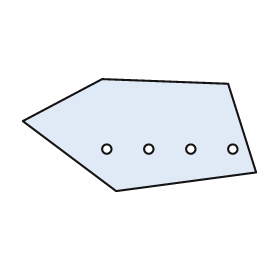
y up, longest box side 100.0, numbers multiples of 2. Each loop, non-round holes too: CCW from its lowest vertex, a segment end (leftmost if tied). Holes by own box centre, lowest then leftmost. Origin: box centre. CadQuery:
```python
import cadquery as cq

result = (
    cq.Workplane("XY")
    .moveTo(-10.0, -24.0)
    .lineTo(50.0, -16.0)
    .lineTo(38.0, 22.0)
    .lineTo(-16.0, 24.0)
    .lineTo(-50.0, 6.0)
    .close()
    .moveTo(-14.0, -6.0)
    .circle(2.0)
    .moveTo(4.0, -6.0)
    .circle(2.0)
    .moveTo(22.0, -6.0)
    .circle(2.0)
    .moveTo(40.0, -6.0)
    .circle(2.0)
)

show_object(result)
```